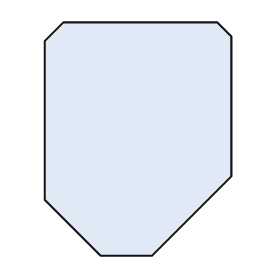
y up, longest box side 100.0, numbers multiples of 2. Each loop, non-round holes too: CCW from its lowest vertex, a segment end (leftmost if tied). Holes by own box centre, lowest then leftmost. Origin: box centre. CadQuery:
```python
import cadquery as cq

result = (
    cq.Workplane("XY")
    .moveTo(-16.0, -50.0)
    .lineTo(6.0, -50.0)
    .lineTo(40.0, -16.0)
    .lineTo(40.0, 44.0)
    .lineTo(34.0, 50.0)
    .lineTo(-32.0, 50.0)
    .lineTo(-40.0, 42.0)
    .lineTo(-40.0, -26.0)
    .close()
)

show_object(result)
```